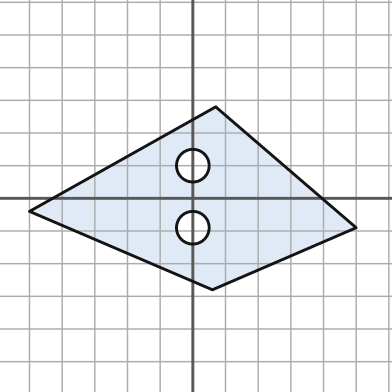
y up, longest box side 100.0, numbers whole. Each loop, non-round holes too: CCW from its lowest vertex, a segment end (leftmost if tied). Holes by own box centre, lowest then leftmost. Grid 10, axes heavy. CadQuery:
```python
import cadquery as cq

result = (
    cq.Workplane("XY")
    .moveTo(6.0, -28.0)
    .lineTo(50.0, -9.0)
    .lineTo(7.0, 28.0)
    .lineTo(-50.0, -4.0)
    .close()
    .moveTo(0.0, -9.0)
    .circle(5.0)
    .moveTo(0.0, 10.0)
    .circle(5.0)
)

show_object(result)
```